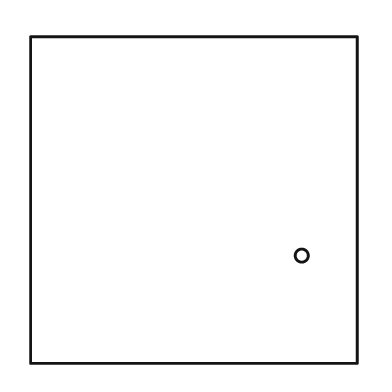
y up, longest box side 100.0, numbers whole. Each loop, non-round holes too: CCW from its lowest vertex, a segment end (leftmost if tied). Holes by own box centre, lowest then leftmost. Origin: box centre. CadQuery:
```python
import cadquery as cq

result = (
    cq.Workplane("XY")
    .moveTo(-50.0, -50.0)
    .lineTo(50.0, -50.0)
    .lineTo(50.0, 50.0)
    .lineTo(-50.0, 50.0)
    .close()
    .moveTo(33.0, -17.0)
    .circle(2.0)
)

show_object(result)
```